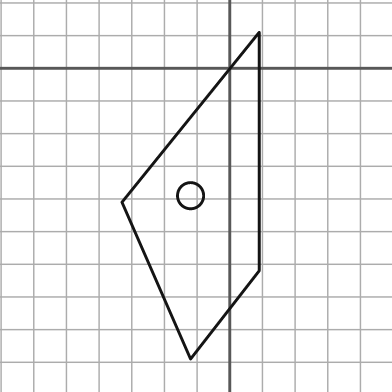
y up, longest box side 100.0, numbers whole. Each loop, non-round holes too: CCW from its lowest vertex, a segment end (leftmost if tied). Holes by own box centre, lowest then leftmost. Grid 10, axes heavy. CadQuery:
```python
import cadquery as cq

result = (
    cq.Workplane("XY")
    .moveTo(-12.0, -89.0)
    .lineTo(9.0, -62.0)
    .lineTo(9.0, 11.0)
    .lineTo(-33.0, -41.0)
    .close()
    .moveTo(-12.0, -39.0)
    .circle(4.0)
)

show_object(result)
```